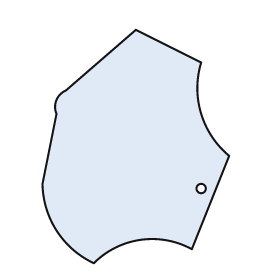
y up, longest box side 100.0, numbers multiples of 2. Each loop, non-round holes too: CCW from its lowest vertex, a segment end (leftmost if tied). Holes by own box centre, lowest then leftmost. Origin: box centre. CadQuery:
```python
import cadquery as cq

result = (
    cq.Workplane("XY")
    .moveTo(-18.0, -50.0)
    .threePointArc((2.0, -40.0), (24.0, -44.0))
    .lineTo(40.0, -4.0)
    .threePointArc((28.0, 14.0), (28.0, 36.0))
    .lineTo(0.0, 50.0)
    .lineTo(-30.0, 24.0)
    .threePointArc((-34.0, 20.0), (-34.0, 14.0))
    .lineTo(-40.0, -16.0)
    .threePointArc((-34.0, -36.0), (-18.0, -50.0))
    .close()
    .moveTo(28.0, -18.0)
    .circle(2.0)
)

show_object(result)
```